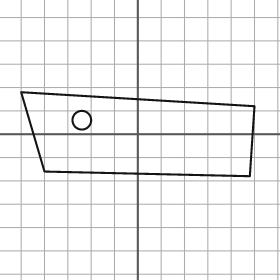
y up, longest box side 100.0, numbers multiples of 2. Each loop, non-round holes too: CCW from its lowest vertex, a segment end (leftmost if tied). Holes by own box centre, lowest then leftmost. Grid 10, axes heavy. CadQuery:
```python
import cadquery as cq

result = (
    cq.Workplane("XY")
    .moveTo(48.0, -18.0)
    .lineTo(50.0, 12.0)
    .lineTo(-50.0, 18.0)
    .lineTo(-40.0, -16.0)
    .close()
    .moveTo(-24.0, 6.0)
    .circle(4.0)
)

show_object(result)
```